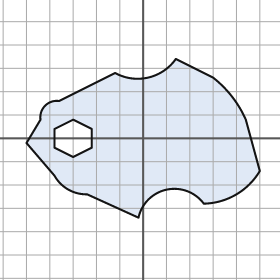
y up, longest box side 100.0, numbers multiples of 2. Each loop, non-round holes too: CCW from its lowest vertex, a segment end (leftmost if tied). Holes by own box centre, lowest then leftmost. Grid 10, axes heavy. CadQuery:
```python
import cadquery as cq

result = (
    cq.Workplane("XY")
    .moveTo(-2.0, -34.0)
    .threePointArc((10.0, -22.0), (26.0, -28.0))
    .threePointArc((40.0, -24.0), (50.0, -14.0))
    .lineTo(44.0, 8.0)
    .threePointArc((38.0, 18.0), (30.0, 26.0))
    .lineTo(14.0, 34.0)
    .threePointArc((2.0, 26.0), (-12.0, 28.0))
    .lineTo(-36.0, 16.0)
    .threePointArc((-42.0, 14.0), (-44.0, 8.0))
    .lineTo(-50.0, -2.0)
    .lineTo(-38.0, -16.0)
    .threePointArc((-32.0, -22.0), (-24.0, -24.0))
    .close()
    .moveTo(-30.0, -8.0)
    .lineTo(-22.0, -4.0)
    .lineTo(-22.0, 4.0)
    .lineTo(-30.0, 8.0)
    .lineTo(-38.0, 4.0)
    .lineTo(-38.0, -4.0)
    .close()
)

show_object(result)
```